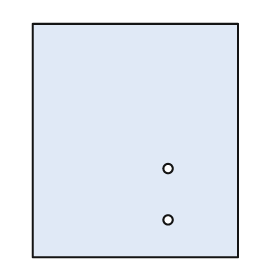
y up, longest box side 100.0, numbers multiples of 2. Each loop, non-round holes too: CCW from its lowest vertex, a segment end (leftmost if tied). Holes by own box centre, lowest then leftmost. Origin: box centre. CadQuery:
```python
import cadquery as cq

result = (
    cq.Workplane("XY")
    .moveTo(-44.0, -50.0)
    .lineTo(44.0, -50.0)
    .lineTo(44.0, 50.0)
    .lineTo(-44.0, 50.0)
    .close()
    .moveTo(14.0, -34.0)
    .circle(2.0)
    .moveTo(14.0, -12.0)
    .circle(2.0)
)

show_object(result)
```